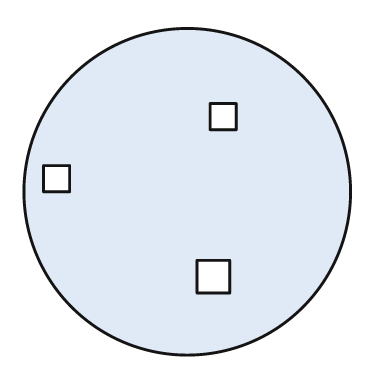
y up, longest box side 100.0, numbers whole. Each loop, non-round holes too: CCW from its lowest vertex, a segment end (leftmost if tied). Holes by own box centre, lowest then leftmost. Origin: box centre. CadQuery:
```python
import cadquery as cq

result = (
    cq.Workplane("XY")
    .moveTo(0.0, 0.0)
    .circle(50.0)
    .moveTo(3.0, -31.0)
    .lineTo(13.0, -31.0)
    .lineTo(13.0, -21.0)
    .lineTo(3.0, -21.0)
    .close()
    .moveTo(-44.0, 0.0)
    .lineTo(-36.0, 0.0)
    .lineTo(-36.0, 8.0)
    .lineTo(-44.0, 8.0)
    .close()
    .moveTo(7.0, 19.0)
    .lineTo(15.0, 19.0)
    .lineTo(15.0, 27.0)
    .lineTo(7.0, 27.0)
    .close()
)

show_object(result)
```